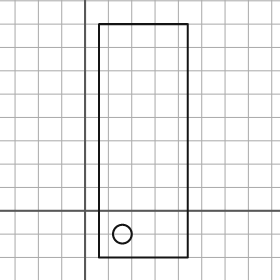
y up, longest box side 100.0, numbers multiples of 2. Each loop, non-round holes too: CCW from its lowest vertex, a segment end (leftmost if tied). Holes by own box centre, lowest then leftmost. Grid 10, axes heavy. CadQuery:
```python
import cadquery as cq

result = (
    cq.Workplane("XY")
    .moveTo(6.0, -20.0)
    .lineTo(44.0, -20.0)
    .lineTo(44.0, 80.0)
    .lineTo(6.0, 80.0)
    .close()
    .moveTo(16.0, -10.0)
    .circle(4.0)
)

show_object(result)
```